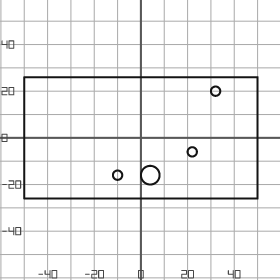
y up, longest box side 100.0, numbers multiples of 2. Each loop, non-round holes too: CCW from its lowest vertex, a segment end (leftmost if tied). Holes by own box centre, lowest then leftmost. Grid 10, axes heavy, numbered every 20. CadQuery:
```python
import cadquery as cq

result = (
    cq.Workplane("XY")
    .moveTo(-50.0, -26.0)
    .lineTo(50.0, -26.0)
    .lineTo(50.0, 26.0)
    .lineTo(-50.0, 26.0)
    .close()
    .moveTo(-10.0, -16.0)
    .circle(2.0)
    .moveTo(4.0, -16.0)
    .circle(4.0)
    .moveTo(22.0, -6.0)
    .circle(2.0)
    .moveTo(32.0, 20.0)
    .circle(2.0)
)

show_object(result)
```